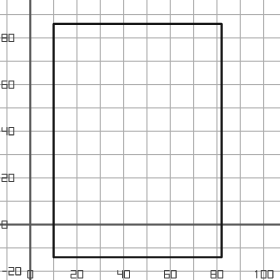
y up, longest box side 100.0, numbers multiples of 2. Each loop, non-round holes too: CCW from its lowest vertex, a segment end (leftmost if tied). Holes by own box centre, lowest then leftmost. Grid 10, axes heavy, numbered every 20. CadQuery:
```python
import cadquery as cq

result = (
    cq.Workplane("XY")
    .moveTo(10.0, -14.0)
    .lineTo(82.0, -14.0)
    .lineTo(82.0, 86.0)
    .lineTo(10.0, 86.0)
    .close()
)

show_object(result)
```